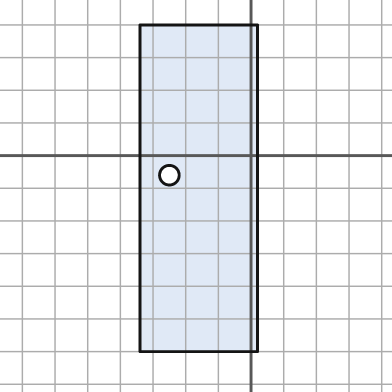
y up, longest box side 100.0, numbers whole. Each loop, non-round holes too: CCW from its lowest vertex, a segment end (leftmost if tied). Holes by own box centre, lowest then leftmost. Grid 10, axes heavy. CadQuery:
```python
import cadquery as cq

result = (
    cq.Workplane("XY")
    .moveTo(-34.0, -60.0)
    .lineTo(2.0, -60.0)
    .lineTo(2.0, 40.0)
    .lineTo(-34.0, 40.0)
    .close()
    .moveTo(-25.0, -6.0)
    .circle(3.0)
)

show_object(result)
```